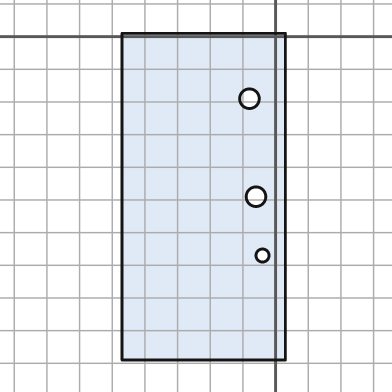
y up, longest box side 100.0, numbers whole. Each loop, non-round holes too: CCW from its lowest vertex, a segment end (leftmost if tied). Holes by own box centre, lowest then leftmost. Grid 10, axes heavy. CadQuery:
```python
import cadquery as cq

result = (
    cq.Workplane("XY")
    .moveTo(-47.0, -99.0)
    .lineTo(3.0, -99.0)
    .lineTo(3.0, 1.0)
    .lineTo(-47.0, 1.0)
    .close()
    .moveTo(-4.0, -67.0)
    .circle(2.0)
    .moveTo(-6.0, -49.0)
    .circle(3.0)
    .moveTo(-8.0, -19.0)
    .circle(3.0)
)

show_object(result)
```